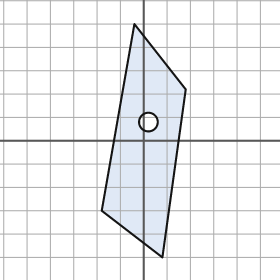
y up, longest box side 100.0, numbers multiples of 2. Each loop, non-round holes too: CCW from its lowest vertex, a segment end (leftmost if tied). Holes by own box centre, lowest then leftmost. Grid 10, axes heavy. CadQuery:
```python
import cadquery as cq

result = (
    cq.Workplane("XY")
    .moveTo(8.0, -50.0)
    .lineTo(18.0, 22.0)
    .lineTo(-4.0, 50.0)
    .lineTo(-18.0, -30.0)
    .close()
    .moveTo(2.0, 8.0)
    .circle(4.0)
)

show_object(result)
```